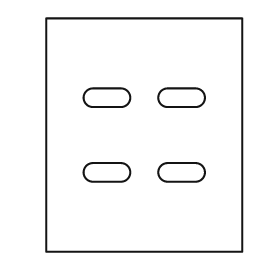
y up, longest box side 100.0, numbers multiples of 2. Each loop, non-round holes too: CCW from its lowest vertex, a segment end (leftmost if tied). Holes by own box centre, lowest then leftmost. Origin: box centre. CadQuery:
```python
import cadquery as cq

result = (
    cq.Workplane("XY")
    .moveTo(-42.0, -50.0)
    .lineTo(42.0, -50.0)
    .lineTo(42.0, 50.0)
    .lineTo(-42.0, 50.0)
    .close()
    .moveTo(-22.0, -20.0)
    .lineTo(-10.0, -20.0)
    .threePointArc((-6.0, -16.0), (-10.0, -12.0))
    .lineTo(-22.0, -12.0)
    .threePointArc((-26.0, -16.0), (-22.0, -20.0))
    .close()
    .moveTo(10.0, -20.0)
    .lineTo(22.0, -20.0)
    .threePointArc((26.0, -16.0), (22.0, -12.0))
    .lineTo(10.0, -12.0)
    .threePointArc((6.0, -16.0), (10.0, -20.0))
    .close()
    .moveTo(-22.0, 12.0)
    .lineTo(-10.0, 12.0)
    .threePointArc((-6.0, 16.0), (-10.0, 20.0))
    .lineTo(-22.0, 20.0)
    .threePointArc((-26.0, 16.0), (-22.0, 12.0))
    .close()
    .moveTo(10.0, 12.0)
    .lineTo(22.0, 12.0)
    .threePointArc((26.0, 16.0), (22.0, 20.0))
    .lineTo(10.0, 20.0)
    .threePointArc((6.0, 16.0), (10.0, 12.0))
    .close()
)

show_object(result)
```